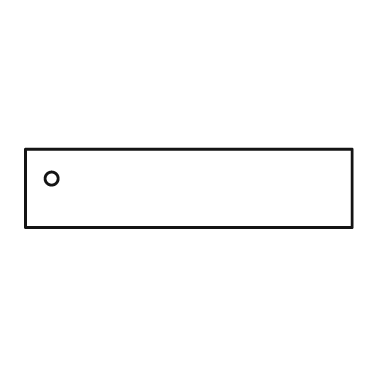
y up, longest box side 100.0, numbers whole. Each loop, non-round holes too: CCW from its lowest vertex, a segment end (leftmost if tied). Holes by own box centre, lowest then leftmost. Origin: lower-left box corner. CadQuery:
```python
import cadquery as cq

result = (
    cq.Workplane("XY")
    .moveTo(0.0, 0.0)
    .lineTo(100.0, 0.0)
    .lineTo(100.0, 24.0)
    .lineTo(0.0, 24.0)
    .close()
    .moveTo(8.0, 15.0)
    .circle(2.0)
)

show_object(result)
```